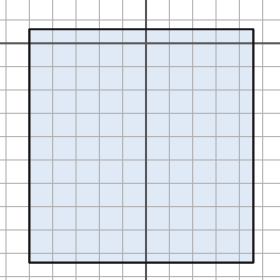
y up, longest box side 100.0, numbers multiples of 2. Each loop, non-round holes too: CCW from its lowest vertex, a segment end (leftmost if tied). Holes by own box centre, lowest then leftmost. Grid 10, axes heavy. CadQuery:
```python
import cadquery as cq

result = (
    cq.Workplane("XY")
    .moveTo(-50.0, -94.0)
    .lineTo(46.0, -94.0)
    .lineTo(46.0, 6.0)
    .lineTo(-50.0, 6.0)
    .close()
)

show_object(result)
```